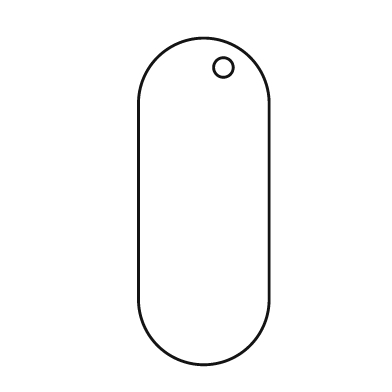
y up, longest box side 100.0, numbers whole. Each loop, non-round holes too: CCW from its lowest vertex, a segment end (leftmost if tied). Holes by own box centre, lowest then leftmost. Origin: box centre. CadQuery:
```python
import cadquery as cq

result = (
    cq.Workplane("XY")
    .moveTo(-20.0, -30.0)
    .threePointArc((0.0, -50.0), (20.0, -30.0))
    .lineTo(20.0, 30.0)
    .threePointArc((0.0, 50.0), (-20.0, 30.0))
    .close()
    .moveTo(6.0, 41.0)
    .circle(3.0)
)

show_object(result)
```